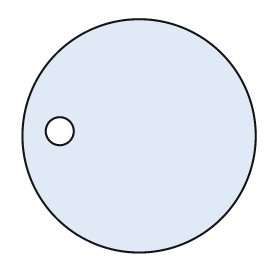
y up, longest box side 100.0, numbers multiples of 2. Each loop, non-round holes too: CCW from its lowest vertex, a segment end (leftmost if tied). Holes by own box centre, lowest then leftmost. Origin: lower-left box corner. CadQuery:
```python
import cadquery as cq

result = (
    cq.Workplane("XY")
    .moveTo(50.0, 50.0)
    .circle(50.0)
    .moveTo(16.0, 52.0)
    .circle(6.0)
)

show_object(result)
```